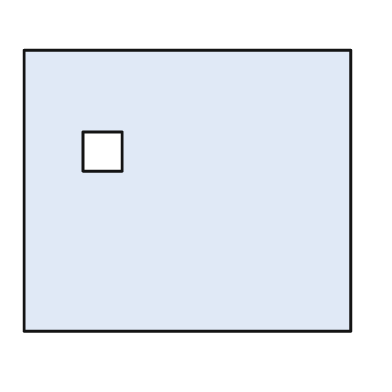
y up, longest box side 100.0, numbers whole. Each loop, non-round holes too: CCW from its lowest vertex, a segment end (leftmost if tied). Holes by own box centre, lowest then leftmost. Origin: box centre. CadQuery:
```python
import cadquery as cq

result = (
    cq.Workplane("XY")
    .moveTo(-50.0, -43.0)
    .lineTo(50.0, -43.0)
    .lineTo(50.0, 43.0)
    .lineTo(-50.0, 43.0)
    .close()
    .moveTo(-32.0, 6.0)
    .lineTo(-20.0, 6.0)
    .lineTo(-20.0, 18.0)
    .lineTo(-32.0, 18.0)
    .close()
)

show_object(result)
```